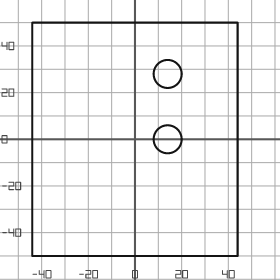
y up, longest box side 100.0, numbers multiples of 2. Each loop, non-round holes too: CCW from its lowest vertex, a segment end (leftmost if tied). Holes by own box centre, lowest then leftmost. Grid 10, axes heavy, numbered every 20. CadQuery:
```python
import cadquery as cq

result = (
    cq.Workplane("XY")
    .moveTo(-44.0, -50.0)
    .lineTo(44.0, -50.0)
    .lineTo(44.0, 50.0)
    .lineTo(-44.0, 50.0)
    .close()
    .moveTo(14.0, 0.0)
    .circle(6.0)
    .moveTo(14.0, 28.0)
    .circle(6.0)
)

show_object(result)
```